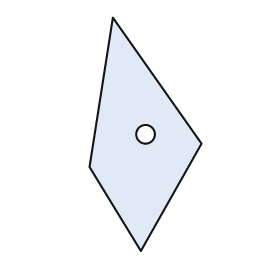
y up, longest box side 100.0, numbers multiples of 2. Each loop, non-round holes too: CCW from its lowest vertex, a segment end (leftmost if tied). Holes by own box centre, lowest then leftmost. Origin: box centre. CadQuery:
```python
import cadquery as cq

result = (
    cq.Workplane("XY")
    .moveTo(-2.0, -50.0)
    .lineTo(24.0, -4.0)
    .lineTo(-14.0, 50.0)
    .lineTo(-24.0, -14.0)
    .close()
    .moveTo(0.0, 0.0)
    .circle(4.0)
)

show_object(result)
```